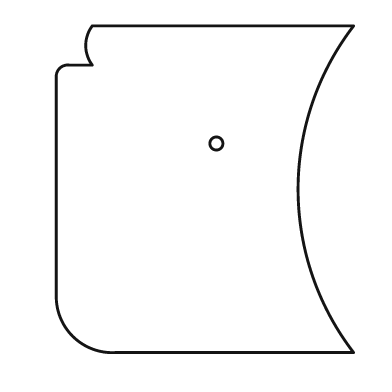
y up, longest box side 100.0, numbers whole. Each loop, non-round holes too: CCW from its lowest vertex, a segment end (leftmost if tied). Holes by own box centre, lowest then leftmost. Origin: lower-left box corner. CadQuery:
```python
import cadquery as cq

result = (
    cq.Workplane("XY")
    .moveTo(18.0, 0.0)
    .lineTo(91.0, 0.0)
    .threePointArc((74.0, 50.0), (91.0, 100.0))
    .lineTo(11.0, 100.0)
    .threePointArc((9.0, 94.0), (11.0, 88.0))
    .lineTo(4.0, 88.0)
    .threePointArc((1.0, 87.0), (0.0, 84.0))
    .lineTo(0.0, 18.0)
    .threePointArc((5.0, 5.0), (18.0, 0.0))
    .close()
    .moveTo(49.0, 64.0)
    .circle(2.0)
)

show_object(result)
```